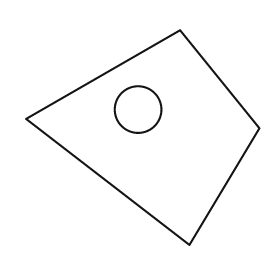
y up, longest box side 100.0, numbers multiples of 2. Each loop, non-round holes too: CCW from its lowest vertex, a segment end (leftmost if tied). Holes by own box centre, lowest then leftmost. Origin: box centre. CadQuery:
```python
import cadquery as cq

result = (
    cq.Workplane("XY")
    .moveTo(20.0, -46.0)
    .lineTo(50.0, 4.0)
    .lineTo(16.0, 46.0)
    .lineTo(-50.0, 8.0)
    .close()
    .moveTo(-2.0, 12.0)
    .circle(10.0)
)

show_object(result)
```